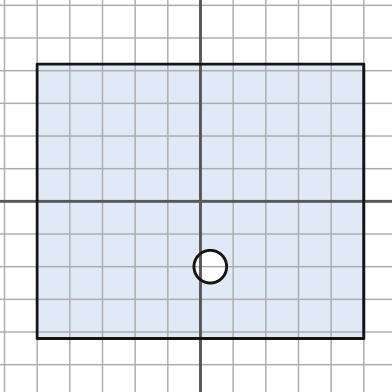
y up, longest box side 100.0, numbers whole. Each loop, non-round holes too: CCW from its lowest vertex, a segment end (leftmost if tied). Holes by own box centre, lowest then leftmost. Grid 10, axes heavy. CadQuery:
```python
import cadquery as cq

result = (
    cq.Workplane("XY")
    .moveTo(-50.0, -42.0)
    .lineTo(50.0, -42.0)
    .lineTo(50.0, 42.0)
    .lineTo(-50.0, 42.0)
    .close()
    .moveTo(3.0, -20.0)
    .circle(5.0)
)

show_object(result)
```